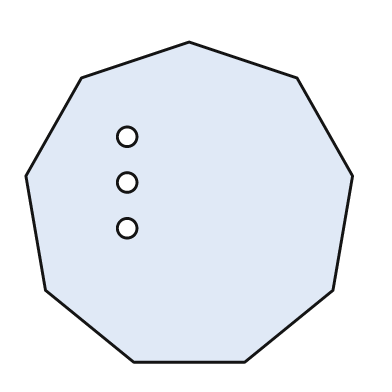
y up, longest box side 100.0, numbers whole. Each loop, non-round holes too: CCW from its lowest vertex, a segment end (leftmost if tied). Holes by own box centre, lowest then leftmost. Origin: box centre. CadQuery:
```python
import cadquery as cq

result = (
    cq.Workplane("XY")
    .moveTo(-17.0, -49.0)
    .lineTo(17.0, -49.0)
    .lineTo(44.0, -27.0)
    .lineTo(50.0, 8.0)
    .lineTo(33.0, 38.0)
    .lineTo(0.0, 49.0)
    .lineTo(-33.0, 38.0)
    .lineTo(-50.0, 8.0)
    .lineTo(-44.0, -27.0)
    .close()
    .moveTo(-19.0, -8.0)
    .circle(3.0)
    .moveTo(-19.0, 6.0)
    .circle(3.0)
    .moveTo(-19.0, 20.0)
    .circle(3.0)
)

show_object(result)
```